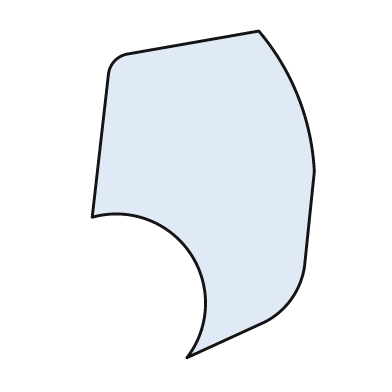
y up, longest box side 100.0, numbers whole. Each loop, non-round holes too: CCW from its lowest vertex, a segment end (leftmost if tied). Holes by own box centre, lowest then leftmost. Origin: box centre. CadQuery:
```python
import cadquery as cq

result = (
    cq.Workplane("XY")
    .moveTo(-5.0, -50.0)
    .lineTo(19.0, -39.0)
    .threePointArc((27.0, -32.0), (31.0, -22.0))
    .lineTo(34.0, 7.0)
    .threePointArc((29.0, 30.0), (17.0, 50.0))
    .lineTo(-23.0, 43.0)
    .threePointArc((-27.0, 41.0), (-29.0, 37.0))
    .lineTo(-34.0, -7.0)
    .threePointArc((-4.0, -18.0), (-5.0, -50.0))
    .close()
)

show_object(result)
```